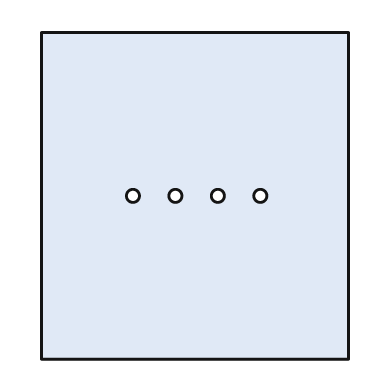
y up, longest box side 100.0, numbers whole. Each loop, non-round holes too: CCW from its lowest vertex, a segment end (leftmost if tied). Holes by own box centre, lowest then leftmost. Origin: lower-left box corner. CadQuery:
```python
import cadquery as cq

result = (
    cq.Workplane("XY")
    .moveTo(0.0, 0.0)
    .lineTo(94.0, 0.0)
    .lineTo(94.0, 100.0)
    .lineTo(0.0, 100.0)
    .close()
    .moveTo(28.0, 50.0)
    .circle(2.0)
    .moveTo(41.0, 50.0)
    .circle(2.0)
    .moveTo(54.0, 50.0)
    .circle(2.0)
    .moveTo(67.0, 50.0)
    .circle(2.0)
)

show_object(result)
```